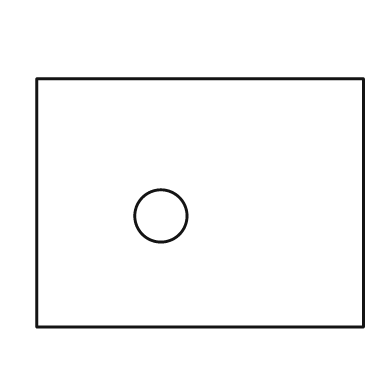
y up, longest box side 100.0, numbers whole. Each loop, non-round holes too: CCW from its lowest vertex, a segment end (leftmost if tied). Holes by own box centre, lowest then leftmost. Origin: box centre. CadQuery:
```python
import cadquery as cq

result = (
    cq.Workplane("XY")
    .moveTo(-50.0, -38.0)
    .lineTo(50.0, -38.0)
    .lineTo(50.0, 38.0)
    .lineTo(-50.0, 38.0)
    .close()
    .moveTo(-12.0, -4.0)
    .circle(8.0)
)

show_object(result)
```